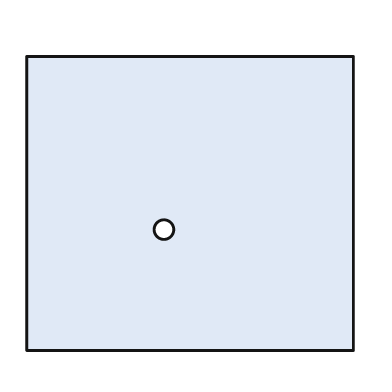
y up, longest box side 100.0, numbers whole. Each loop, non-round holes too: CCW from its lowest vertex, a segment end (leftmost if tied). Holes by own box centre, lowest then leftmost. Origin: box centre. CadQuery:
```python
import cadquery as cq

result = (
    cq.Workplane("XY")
    .moveTo(-50.0, -45.0)
    .lineTo(50.0, -45.0)
    .lineTo(50.0, 45.0)
    .lineTo(-50.0, 45.0)
    .close()
    .moveTo(-8.0, -8.0)
    .circle(3.0)
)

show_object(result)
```